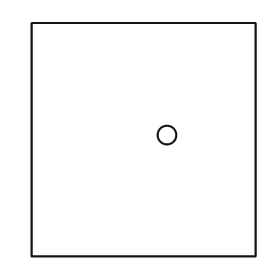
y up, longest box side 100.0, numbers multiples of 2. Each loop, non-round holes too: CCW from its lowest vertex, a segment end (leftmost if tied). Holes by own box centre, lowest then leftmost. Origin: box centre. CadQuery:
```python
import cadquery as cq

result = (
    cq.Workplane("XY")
    .moveTo(-48.0, -50.0)
    .lineTo(48.0, -50.0)
    .lineTo(48.0, 50.0)
    .lineTo(-48.0, 50.0)
    .close()
    .moveTo(10.0, 2.0)
    .circle(4.0)
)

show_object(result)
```